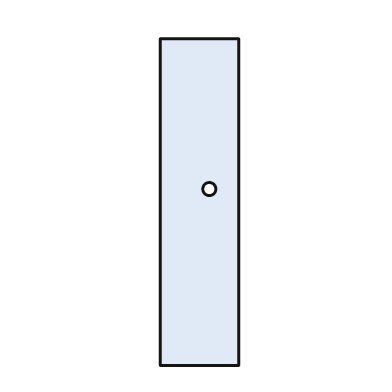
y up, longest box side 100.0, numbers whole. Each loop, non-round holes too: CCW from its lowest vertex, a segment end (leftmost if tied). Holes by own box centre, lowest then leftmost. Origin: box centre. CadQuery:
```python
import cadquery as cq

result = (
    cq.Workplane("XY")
    .moveTo(-12.0, -50.0)
    .lineTo(12.0, -50.0)
    .lineTo(12.0, 50.0)
    .lineTo(-12.0, 50.0)
    .close()
    .moveTo(3.0, 4.0)
    .circle(2.0)
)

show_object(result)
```